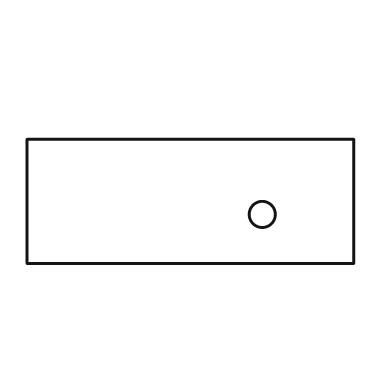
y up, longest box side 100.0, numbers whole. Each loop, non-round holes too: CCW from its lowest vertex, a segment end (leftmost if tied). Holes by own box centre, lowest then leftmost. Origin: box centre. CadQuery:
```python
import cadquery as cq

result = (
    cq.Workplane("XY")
    .moveTo(-50.0, -19.0)
    .lineTo(50.0, -19.0)
    .lineTo(50.0, 19.0)
    .lineTo(-50.0, 19.0)
    .close()
    .moveTo(22.0, -4.0)
    .circle(4.0)
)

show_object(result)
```